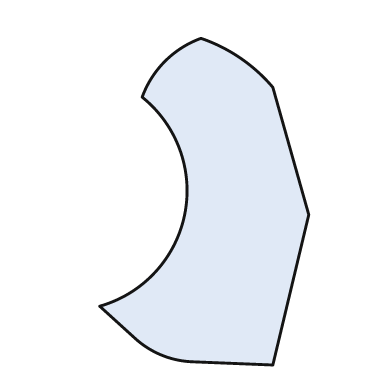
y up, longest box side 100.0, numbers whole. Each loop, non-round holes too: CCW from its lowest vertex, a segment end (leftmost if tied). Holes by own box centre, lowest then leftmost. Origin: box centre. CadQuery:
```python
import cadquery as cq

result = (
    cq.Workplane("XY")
    .moveTo(21.0, -50.0)
    .lineTo(32.0, -4.0)
    .lineTo(21.0, 35.0)
    .threePointArc((11.0, 44.0), (-1.0, 50.0))
    .threePointArc((-12.0, 43.0), (-19.0, 32.0))
    .threePointArc((-6.0, -4.0), (-32.0, -32.0))
    .lineTo(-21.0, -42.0)
    .threePointArc((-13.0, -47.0), (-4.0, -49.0))
    .close()
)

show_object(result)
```